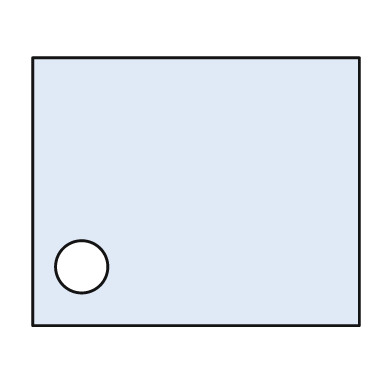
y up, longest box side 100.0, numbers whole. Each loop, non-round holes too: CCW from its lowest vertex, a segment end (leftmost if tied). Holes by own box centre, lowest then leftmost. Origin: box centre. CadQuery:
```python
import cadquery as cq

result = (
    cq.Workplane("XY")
    .moveTo(-50.0, -41.0)
    .lineTo(50.0, -41.0)
    .lineTo(50.0, 41.0)
    .lineTo(-50.0, 41.0)
    .close()
    .moveTo(-35.0, -23.0)
    .circle(8.0)
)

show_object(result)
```